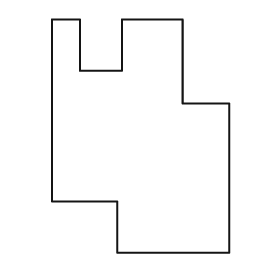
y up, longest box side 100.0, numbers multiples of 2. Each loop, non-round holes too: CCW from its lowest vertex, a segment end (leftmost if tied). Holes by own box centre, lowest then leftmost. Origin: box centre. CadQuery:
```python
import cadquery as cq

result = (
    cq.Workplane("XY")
    .moveTo(-10.0, -50.0)
    .lineTo(38.0, -50.0)
    .lineTo(38.0, 14.0)
    .lineTo(18.0, 14.0)
    .lineTo(18.0, 50.0)
    .lineTo(-8.0, 50.0)
    .lineTo(-8.0, 28.0)
    .lineTo(-26.0, 28.0)
    .lineTo(-26.0, 50.0)
    .lineTo(-38.0, 50.0)
    .lineTo(-38.0, -28.0)
    .lineTo(-10.0, -28.0)
    .close()
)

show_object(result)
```